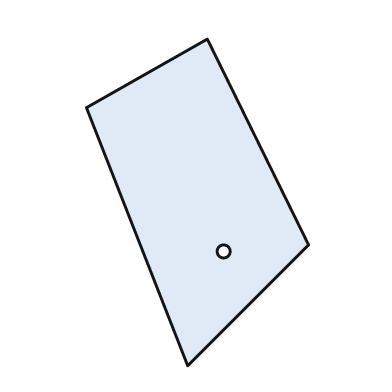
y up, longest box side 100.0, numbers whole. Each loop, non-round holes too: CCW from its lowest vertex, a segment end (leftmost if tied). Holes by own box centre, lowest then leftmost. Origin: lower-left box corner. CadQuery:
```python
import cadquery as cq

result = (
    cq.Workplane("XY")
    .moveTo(31.0, 0.0)
    .lineTo(68.0, 37.0)
    .lineTo(37.0, 100.0)
    .lineTo(0.0, 79.0)
    .close()
    .moveTo(42.0, 35.0)
    .circle(2.0)
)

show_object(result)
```